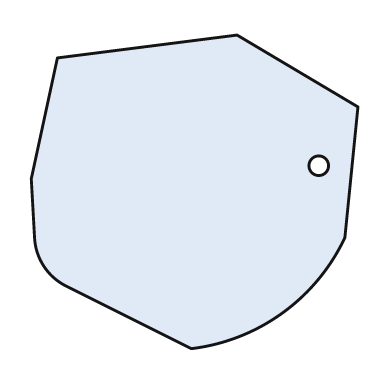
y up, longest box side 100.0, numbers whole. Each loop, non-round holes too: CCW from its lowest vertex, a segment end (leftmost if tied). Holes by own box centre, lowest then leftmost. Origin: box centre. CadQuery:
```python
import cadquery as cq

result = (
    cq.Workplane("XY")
    .moveTo(-1.0, -48.0)
    .threePointArc((27.0, -37.0), (46.0, -14.0))
    .lineTo(50.0, 26.0)
    .lineTo(13.0, 48.0)
    .lineTo(-42.0, 41.0)
    .lineTo(-50.0, 4.0)
    .lineTo(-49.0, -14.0)
    .threePointArc((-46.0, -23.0), (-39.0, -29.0))
    .close()
    .moveTo(38.0, 8.0)
    .circle(3.0)
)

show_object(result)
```